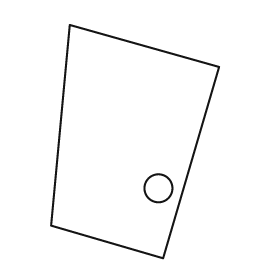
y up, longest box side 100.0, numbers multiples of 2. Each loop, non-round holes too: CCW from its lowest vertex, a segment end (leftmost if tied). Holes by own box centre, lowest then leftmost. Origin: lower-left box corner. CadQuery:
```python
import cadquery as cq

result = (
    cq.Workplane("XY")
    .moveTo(48.0, 0.0)
    .lineTo(72.0, 82.0)
    .lineTo(8.0, 100.0)
    .lineTo(0.0, 14.0)
    .close()
    .moveTo(46.0, 30.0)
    .circle(6.0)
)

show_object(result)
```